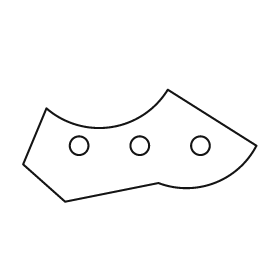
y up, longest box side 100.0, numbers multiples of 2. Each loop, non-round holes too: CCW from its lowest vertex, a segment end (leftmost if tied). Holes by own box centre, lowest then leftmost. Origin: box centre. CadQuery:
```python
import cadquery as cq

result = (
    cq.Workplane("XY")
    .moveTo(-32.0, -24.0)
    .lineTo(8.0, -16.0)
    .threePointArc((32.0, -16.0), (50.0, 0.0))
    .lineTo(12.0, 24.0)
    .threePointArc((-12.0, 8.0), (-40.0, 16.0))
    .lineTo(-50.0, -8.0)
    .close()
    .moveTo(-26.0, 0.0)
    .circle(4.0)
    .moveTo(0.0, 0.0)
    .circle(4.0)
    .moveTo(26.0, 0.0)
    .circle(4.0)
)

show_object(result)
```